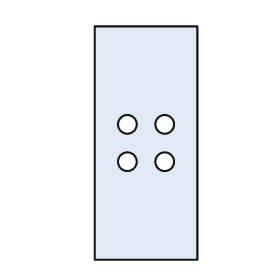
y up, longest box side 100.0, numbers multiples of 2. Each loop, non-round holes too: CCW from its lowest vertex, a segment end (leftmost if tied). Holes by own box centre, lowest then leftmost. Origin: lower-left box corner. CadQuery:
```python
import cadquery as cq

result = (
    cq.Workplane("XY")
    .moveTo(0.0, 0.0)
    .lineTo(44.0, 0.0)
    .lineTo(44.0, 100.0)
    .lineTo(0.0, 100.0)
    .close()
    .moveTo(14.0, 42.0)
    .circle(4.0)
    .moveTo(30.0, 42.0)
    .circle(4.0)
    .moveTo(14.0, 58.0)
    .circle(4.0)
    .moveTo(30.0, 58.0)
    .circle(4.0)
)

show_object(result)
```